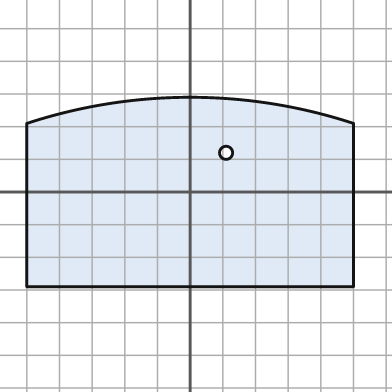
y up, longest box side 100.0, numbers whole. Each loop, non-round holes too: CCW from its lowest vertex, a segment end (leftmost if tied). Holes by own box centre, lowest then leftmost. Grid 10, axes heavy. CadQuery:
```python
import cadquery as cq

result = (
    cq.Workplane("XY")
    .moveTo(-50.0, -29.0)
    .lineTo(50.0, -29.0)
    .lineTo(50.0, 21.0)
    .threePointArc((0.0, 29.0), (-50.0, 21.0))
    .close()
    .moveTo(11.0, 12.0)
    .circle(2.0)
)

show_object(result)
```